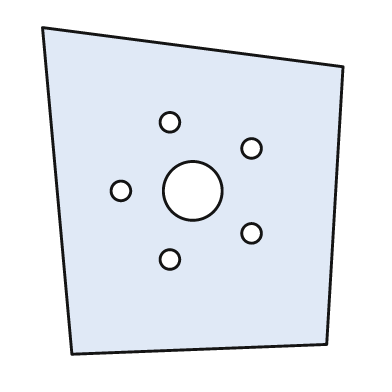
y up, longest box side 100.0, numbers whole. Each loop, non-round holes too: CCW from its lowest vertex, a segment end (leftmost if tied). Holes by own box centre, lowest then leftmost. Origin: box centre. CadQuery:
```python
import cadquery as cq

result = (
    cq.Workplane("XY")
    .moveTo(-37.0, -50.0)
    .lineTo(41.0, -47.0)
    .lineTo(46.0, 38.0)
    .lineTo(-46.0, 50.0)
    .close()
    .moveTo(-7.0, -21.0)
    .circle(3.0)
    .moveTo(18.0, -13.0)
    .circle(3.0)
    .moveTo(-22.0, 0.0)
    .circle(3.0)
    .moveTo(0.0, 0.0)
    .circle(9.0)
    .moveTo(18.0, 13.0)
    .circle(3.0)
    .moveTo(-7.0, 21.0)
    .circle(3.0)
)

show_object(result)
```